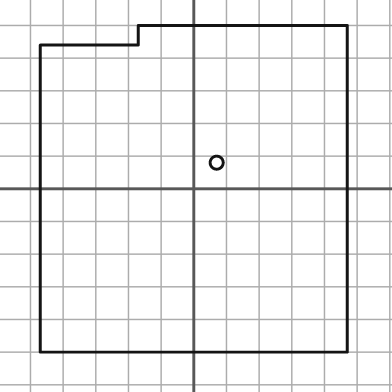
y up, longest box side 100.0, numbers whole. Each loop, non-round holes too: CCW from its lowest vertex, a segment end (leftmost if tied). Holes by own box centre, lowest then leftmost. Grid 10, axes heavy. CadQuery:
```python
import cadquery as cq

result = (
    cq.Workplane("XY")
    .moveTo(-47.0, -50.0)
    .lineTo(47.0, -50.0)
    .lineTo(47.0, 50.0)
    .lineTo(-17.0, 50.0)
    .lineTo(-17.0, 44.0)
    .lineTo(-47.0, 44.0)
    .close()
    .moveTo(7.0, 8.0)
    .circle(2.0)
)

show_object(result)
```